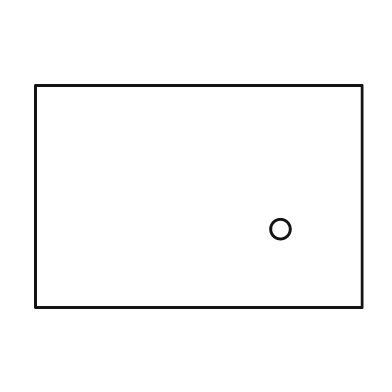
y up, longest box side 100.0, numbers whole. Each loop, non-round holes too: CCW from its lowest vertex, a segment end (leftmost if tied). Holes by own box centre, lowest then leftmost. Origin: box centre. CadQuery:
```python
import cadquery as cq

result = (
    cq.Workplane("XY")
    .moveTo(-50.0, -34.0)
    .lineTo(50.0, -34.0)
    .lineTo(50.0, 34.0)
    .lineTo(-50.0, 34.0)
    .close()
    .moveTo(25.0, -10.0)
    .circle(3.0)
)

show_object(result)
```